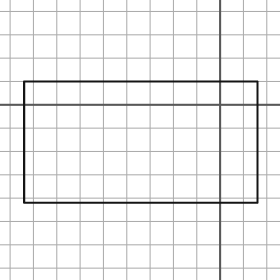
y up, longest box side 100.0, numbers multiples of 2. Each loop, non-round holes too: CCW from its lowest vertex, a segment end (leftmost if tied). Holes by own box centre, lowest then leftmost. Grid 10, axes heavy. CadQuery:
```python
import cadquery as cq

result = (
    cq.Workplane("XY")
    .moveTo(-84.0, -42.0)
    .lineTo(16.0, -42.0)
    .lineTo(16.0, 10.0)
    .lineTo(-84.0, 10.0)
    .close()
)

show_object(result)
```